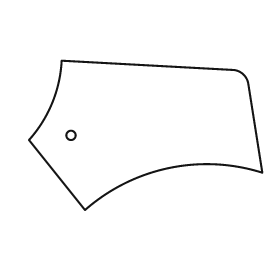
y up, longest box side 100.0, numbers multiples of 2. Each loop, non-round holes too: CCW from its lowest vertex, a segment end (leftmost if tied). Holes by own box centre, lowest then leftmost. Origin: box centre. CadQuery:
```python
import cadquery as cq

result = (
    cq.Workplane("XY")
    .moveTo(-26.0, -32.0)
    .threePointArc((10.0, -14.0), (50.0, -16.0))
    .lineTo(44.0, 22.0)
    .threePointArc((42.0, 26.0), (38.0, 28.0))
    .lineTo(-36.0, 32.0)
    .threePointArc((-40.0, 14.0), (-50.0, -2.0))
    .close()
    .moveTo(-32.0, 0.0)
    .circle(2.0)
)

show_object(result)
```